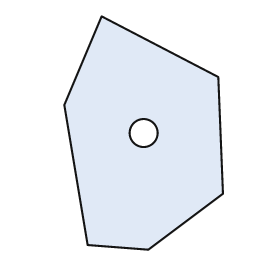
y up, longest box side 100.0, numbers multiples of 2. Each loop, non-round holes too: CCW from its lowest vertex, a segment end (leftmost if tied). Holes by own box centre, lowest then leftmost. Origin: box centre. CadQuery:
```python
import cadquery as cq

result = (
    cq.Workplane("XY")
    .moveTo(2.0, -50.0)
    .lineTo(34.0, -26.0)
    .lineTo(32.0, 24.0)
    .lineTo(-18.0, 50.0)
    .lineTo(-34.0, 12.0)
    .lineTo(-24.0, -48.0)
    .close()
    .moveTo(0.0, 0.0)
    .circle(6.0)
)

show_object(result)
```